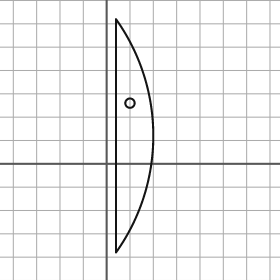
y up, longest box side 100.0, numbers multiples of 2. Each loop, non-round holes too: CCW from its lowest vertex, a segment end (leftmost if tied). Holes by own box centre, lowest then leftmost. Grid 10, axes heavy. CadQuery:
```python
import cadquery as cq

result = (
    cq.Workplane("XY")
    .moveTo(4.0, -38.0)
    .threePointArc((20.0, 12.0), (4.0, 62.0))
    .close()
    .moveTo(10.0, 26.0)
    .circle(2.0)
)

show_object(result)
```